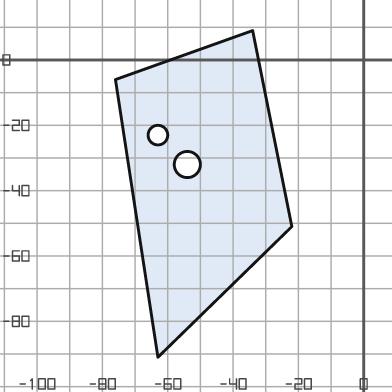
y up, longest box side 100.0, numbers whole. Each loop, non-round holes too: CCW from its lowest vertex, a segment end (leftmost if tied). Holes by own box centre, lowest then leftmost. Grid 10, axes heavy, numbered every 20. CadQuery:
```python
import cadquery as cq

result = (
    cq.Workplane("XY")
    .moveTo(-63.0, -91.0)
    .lineTo(-22.0, -51.0)
    .lineTo(-34.0, 9.0)
    .lineTo(-76.0, -6.0)
    .close()
    .moveTo(-54.0, -32.0)
    .circle(4.0)
    .moveTo(-63.0, -23.0)
    .circle(3.0)
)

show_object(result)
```